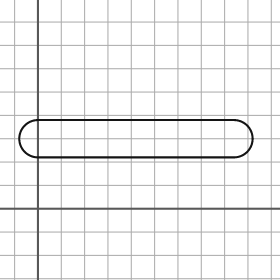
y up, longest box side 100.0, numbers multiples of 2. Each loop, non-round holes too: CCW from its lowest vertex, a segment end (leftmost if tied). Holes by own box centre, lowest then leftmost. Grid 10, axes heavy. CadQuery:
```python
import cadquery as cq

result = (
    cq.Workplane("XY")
    .moveTo(0.0, 22.0)
    .lineTo(84.0, 22.0)
    .threePointArc((92.0, 30.0), (84.0, 38.0))
    .lineTo(0.0, 38.0)
    .threePointArc((-8.0, 30.0), (0.0, 22.0))
    .close()
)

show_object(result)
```